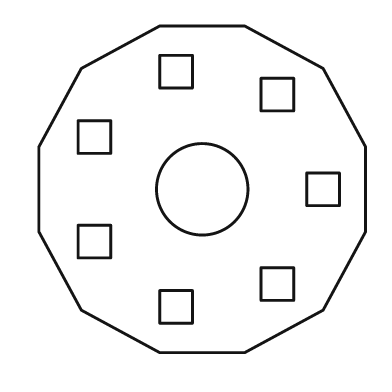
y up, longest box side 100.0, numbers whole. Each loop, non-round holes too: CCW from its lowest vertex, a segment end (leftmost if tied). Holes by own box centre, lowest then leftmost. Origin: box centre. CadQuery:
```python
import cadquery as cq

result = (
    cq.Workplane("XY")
    .moveTo(-13.0, -50.0)
    .lineTo(13.0, -50.0)
    .lineTo(37.0, -37.0)
    .lineTo(50.0, -13.0)
    .lineTo(50.0, 13.0)
    .lineTo(37.0, 37.0)
    .lineTo(13.0, 50.0)
    .lineTo(-13.0, 50.0)
    .lineTo(-37.0, 37.0)
    .lineTo(-50.0, 13.0)
    .lineTo(-50.0, -13.0)
    .lineTo(-37.0, -37.0)
    .close()
    .moveTo(-13.0, -41.0)
    .lineTo(-3.0, -41.0)
    .lineTo(-3.0, -31.0)
    .lineTo(-13.0, -31.0)
    .close()
    .moveTo(18.0, -34.0)
    .lineTo(28.0, -34.0)
    .lineTo(28.0, -24.0)
    .lineTo(18.0, -24.0)
    .close()
    .moveTo(-38.0, -21.0)
    .lineTo(-28.0, -21.0)
    .lineTo(-28.0, -11.0)
    .lineTo(-38.0, -11.0)
    .close()
    .moveTo(0.0, 0.0)
    .circle(14.0)
    .moveTo(32.0, -5.0)
    .lineTo(42.0, -5.0)
    .lineTo(42.0, 5.0)
    .lineTo(32.0, 5.0)
    .close()
    .moveTo(-38.0, 11.0)
    .lineTo(-28.0, 11.0)
    .lineTo(-28.0, 21.0)
    .lineTo(-38.0, 21.0)
    .close()
    .moveTo(18.0, 24.0)
    .lineTo(28.0, 24.0)
    .lineTo(28.0, 34.0)
    .lineTo(18.0, 34.0)
    .close()
    .moveTo(-13.0, 31.0)
    .lineTo(-3.0, 31.0)
    .lineTo(-3.0, 41.0)
    .lineTo(-13.0, 41.0)
    .close()
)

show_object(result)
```